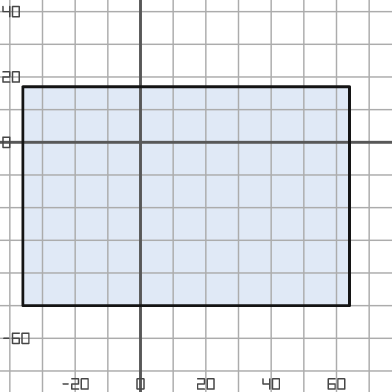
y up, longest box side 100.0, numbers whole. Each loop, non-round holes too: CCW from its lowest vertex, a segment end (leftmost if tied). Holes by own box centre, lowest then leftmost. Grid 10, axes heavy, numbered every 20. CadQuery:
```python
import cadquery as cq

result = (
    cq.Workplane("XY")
    .moveTo(-36.0, -50.0)
    .lineTo(64.0, -50.0)
    .lineTo(64.0, 17.0)
    .lineTo(-36.0, 17.0)
    .close()
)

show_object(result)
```